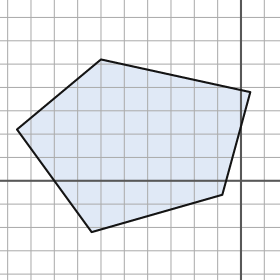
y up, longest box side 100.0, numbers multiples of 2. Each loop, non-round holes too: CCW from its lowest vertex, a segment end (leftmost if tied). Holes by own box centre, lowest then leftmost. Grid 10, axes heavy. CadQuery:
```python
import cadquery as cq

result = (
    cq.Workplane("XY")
    .moveTo(-64.0, -22.0)
    .lineTo(-8.0, -6.0)
    .lineTo(4.0, 38.0)
    .lineTo(-60.0, 52.0)
    .lineTo(-96.0, 22.0)
    .close()
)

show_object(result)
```